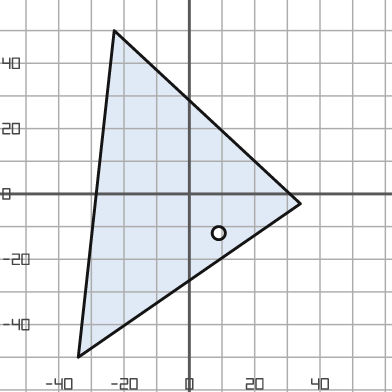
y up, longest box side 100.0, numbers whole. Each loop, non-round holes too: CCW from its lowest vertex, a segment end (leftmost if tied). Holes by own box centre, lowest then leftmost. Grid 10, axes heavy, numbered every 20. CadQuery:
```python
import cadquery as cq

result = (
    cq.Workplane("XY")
    .moveTo(-34.0, -50.0)
    .lineTo(34.0, -3.0)
    .lineTo(-23.0, 50.0)
    .close()
    .moveTo(9.0, -12.0)
    .circle(2.0)
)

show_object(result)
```